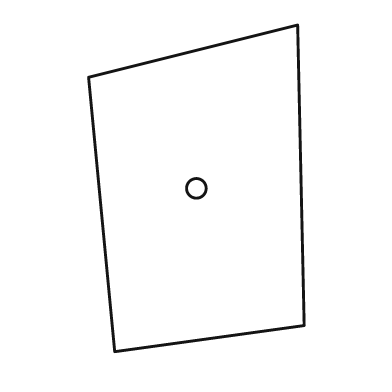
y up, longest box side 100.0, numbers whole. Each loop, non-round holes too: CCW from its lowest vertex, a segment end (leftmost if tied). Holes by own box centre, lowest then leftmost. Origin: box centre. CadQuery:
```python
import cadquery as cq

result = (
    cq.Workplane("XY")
    .moveTo(-25.0, -50.0)
    .lineTo(33.0, -42.0)
    .lineTo(31.0, 50.0)
    .lineTo(-33.0, 34.0)
    .close()
    .moveTo(0.0, 0.0)
    .circle(3.0)
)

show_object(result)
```